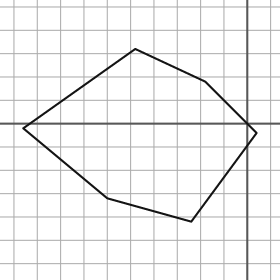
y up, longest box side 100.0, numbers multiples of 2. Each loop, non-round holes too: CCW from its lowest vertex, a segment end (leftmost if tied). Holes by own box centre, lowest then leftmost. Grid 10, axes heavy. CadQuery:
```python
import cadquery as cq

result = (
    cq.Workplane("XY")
    .moveTo(-24.0, -42.0)
    .lineTo(4.0, -4.0)
    .lineTo(-18.0, 18.0)
    .lineTo(-48.0, 32.0)
    .lineTo(-96.0, -2.0)
    .lineTo(-60.0, -32.0)
    .close()
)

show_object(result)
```